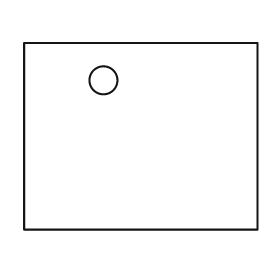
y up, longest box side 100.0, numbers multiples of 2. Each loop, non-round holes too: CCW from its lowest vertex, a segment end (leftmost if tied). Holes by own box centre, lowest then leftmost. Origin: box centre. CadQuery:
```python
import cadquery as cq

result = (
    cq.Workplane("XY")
    .moveTo(-50.0, -40.0)
    .lineTo(50.0, -40.0)
    .lineTo(50.0, 40.0)
    .lineTo(-50.0, 40.0)
    .close()
    .moveTo(-16.0, 24.0)
    .circle(6.0)
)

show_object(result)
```